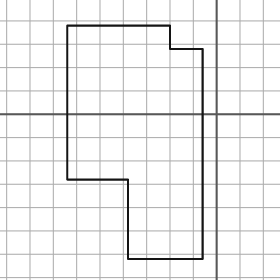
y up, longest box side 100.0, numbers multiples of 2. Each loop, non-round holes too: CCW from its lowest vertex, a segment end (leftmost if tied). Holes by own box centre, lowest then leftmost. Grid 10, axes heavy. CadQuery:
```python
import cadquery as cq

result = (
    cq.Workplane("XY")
    .moveTo(-38.0, -62.0)
    .lineTo(-6.0, -62.0)
    .lineTo(-6.0, 28.0)
    .lineTo(-20.0, 28.0)
    .lineTo(-20.0, 38.0)
    .lineTo(-64.0, 38.0)
    .lineTo(-64.0, -28.0)
    .lineTo(-38.0, -28.0)
    .close()
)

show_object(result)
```